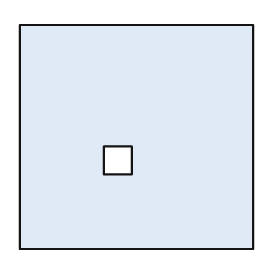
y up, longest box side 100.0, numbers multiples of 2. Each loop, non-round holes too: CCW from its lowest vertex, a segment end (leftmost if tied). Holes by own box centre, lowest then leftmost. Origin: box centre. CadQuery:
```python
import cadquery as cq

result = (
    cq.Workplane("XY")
    .moveTo(-50.0, -48.0)
    .lineTo(50.0, -48.0)
    .lineTo(50.0, 48.0)
    .lineTo(-50.0, 48.0)
    .close()
    .moveTo(-14.0, -16.0)
    .lineTo(-2.0, -16.0)
    .lineTo(-2.0, -4.0)
    .lineTo(-14.0, -4.0)
    .close()
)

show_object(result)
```